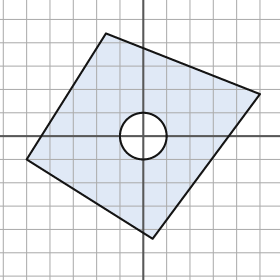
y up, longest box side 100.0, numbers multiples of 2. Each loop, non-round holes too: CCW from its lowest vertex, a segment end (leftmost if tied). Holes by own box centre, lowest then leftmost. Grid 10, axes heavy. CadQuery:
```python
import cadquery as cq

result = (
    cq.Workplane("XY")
    .moveTo(4.0, -44.0)
    .lineTo(50.0, 18.0)
    .lineTo(-16.0, 44.0)
    .lineTo(-50.0, -10.0)
    .close()
    .moveTo(0.0, 0.0)
    .circle(10.0)
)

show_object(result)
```